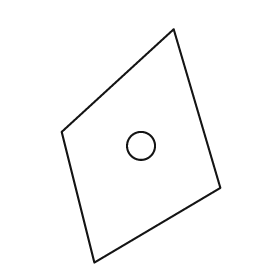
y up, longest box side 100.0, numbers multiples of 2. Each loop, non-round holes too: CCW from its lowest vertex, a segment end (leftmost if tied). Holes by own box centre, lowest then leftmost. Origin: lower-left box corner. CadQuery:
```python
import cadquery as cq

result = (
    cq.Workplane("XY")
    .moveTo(14.0, 0.0)
    .lineTo(68.0, 32.0)
    .lineTo(48.0, 100.0)
    .lineTo(0.0, 56.0)
    .close()
    .moveTo(34.0, 50.0)
    .circle(6.0)
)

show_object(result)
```